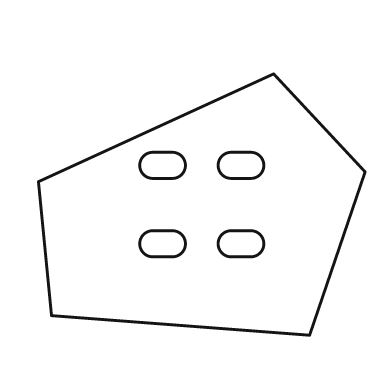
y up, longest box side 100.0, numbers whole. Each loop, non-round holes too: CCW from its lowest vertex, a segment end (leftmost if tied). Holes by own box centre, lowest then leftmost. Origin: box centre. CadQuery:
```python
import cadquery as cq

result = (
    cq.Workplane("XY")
    .moveTo(33.0, -40.0)
    .lineTo(50.0, 10.0)
    .lineTo(22.0, 40.0)
    .lineTo(-50.0, 7.0)
    .lineTo(-46.0, -34.0)
    .close()
    .moveTo(-15.0, -16.0)
    .lineTo(-9.0, -16.0)
    .threePointArc((-5.0, -12.0), (-9.0, -8.0))
    .lineTo(-15.0, -8.0)
    .threePointArc((-19.0, -12.0), (-15.0, -16.0))
    .close()
    .moveTo(9.0, -16.0)
    .lineTo(15.0, -16.0)
    .threePointArc((19.0, -12.0), (15.0, -8.0))
    .lineTo(9.0, -8.0)
    .threePointArc((5.0, -12.0), (9.0, -16.0))
    .close()
    .moveTo(-15.0, 8.0)
    .lineTo(-9.0, 8.0)
    .threePointArc((-5.0, 12.0), (-9.0, 16.0))
    .lineTo(-15.0, 16.0)
    .threePointArc((-19.0, 12.0), (-15.0, 8.0))
    .close()
    .moveTo(9.0, 8.0)
    .lineTo(15.0, 8.0)
    .threePointArc((19.0, 12.0), (15.0, 16.0))
    .lineTo(9.0, 16.0)
    .threePointArc((5.0, 12.0), (9.0, 8.0))
    .close()
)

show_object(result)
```